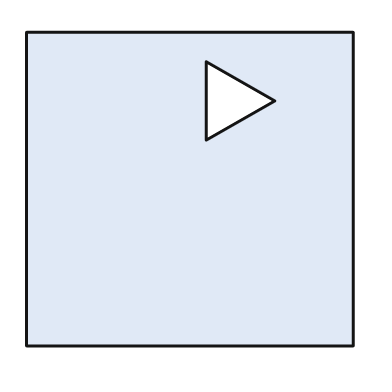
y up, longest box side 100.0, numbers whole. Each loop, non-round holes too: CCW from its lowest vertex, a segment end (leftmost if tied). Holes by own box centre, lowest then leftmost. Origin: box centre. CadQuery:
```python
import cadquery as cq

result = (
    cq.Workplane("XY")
    .moveTo(-50.0, -48.0)
    .lineTo(50.0, -48.0)
    .lineTo(50.0, 48.0)
    .lineTo(-50.0, 48.0)
    .close()
    .moveTo(5.0, 15.0)
    .lineTo(26.0, 27.0)
    .lineTo(5.0, 39.0)
    .close()
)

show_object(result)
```